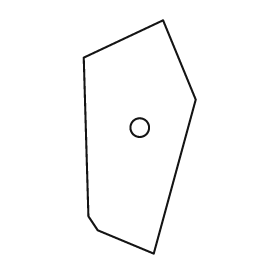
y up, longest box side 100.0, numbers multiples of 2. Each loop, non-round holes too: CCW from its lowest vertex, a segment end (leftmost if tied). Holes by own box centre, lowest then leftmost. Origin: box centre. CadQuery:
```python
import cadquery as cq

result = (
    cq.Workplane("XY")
    .moveTo(6.0, -50.0)
    .lineTo(24.0, 16.0)
    .lineTo(10.0, 50.0)
    .lineTo(-24.0, 34.0)
    .lineTo(-22.0, -34.0)
    .lineTo(-18.0, -40.0)
    .close()
    .moveTo(0.0, 4.0)
    .circle(4.0)
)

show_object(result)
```